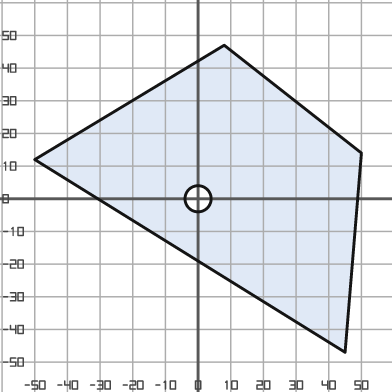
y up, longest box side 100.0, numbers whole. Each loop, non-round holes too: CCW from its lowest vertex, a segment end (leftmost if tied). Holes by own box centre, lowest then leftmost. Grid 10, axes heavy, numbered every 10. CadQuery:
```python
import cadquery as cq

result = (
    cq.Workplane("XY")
    .moveTo(45.0, -47.0)
    .lineTo(50.0, 14.0)
    .lineTo(8.0, 47.0)
    .lineTo(-50.0, 12.0)
    .close()
    .moveTo(0.0, 0.0)
    .circle(4.0)
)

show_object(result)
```